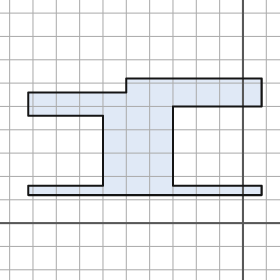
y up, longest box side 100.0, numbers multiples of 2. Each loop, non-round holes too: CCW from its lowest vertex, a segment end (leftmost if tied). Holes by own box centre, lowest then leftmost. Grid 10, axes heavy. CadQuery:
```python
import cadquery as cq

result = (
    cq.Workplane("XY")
    .moveTo(-92.0, 12.0)
    .lineTo(8.0, 12.0)
    .lineTo(8.0, 16.0)
    .lineTo(-30.0, 16.0)
    .lineTo(-30.0, 50.0)
    .lineTo(8.0, 50.0)
    .lineTo(8.0, 62.0)
    .lineTo(-50.0, 62.0)
    .lineTo(-50.0, 56.0)
    .lineTo(-92.0, 56.0)
    .lineTo(-92.0, 46.0)
    .lineTo(-60.0, 46.0)
    .lineTo(-60.0, 16.0)
    .lineTo(-92.0, 16.0)
    .close()
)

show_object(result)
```